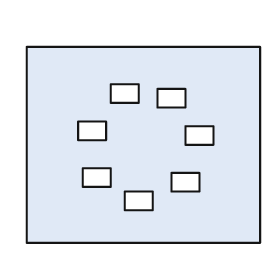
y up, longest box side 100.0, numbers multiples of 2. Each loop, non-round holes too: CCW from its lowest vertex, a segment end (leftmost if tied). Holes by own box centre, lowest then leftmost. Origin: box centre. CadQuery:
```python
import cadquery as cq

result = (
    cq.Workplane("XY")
    .moveTo(-50.0, -42.0)
    .lineTo(50.0, -42.0)
    .lineTo(50.0, 42.0)
    .lineTo(-50.0, 42.0)
    .close()
    .moveTo(-8.0, -28.0)
    .lineTo(4.0, -28.0)
    .lineTo(4.0, -20.0)
    .lineTo(-8.0, -20.0)
    .close()
    .moveTo(12.0, -20.0)
    .lineTo(24.0, -20.0)
    .lineTo(24.0, -12.0)
    .lineTo(12.0, -12.0)
    .close()
    .moveTo(-26.0, -18.0)
    .lineTo(-14.0, -18.0)
    .lineTo(-14.0, -10.0)
    .lineTo(-26.0, -10.0)
    .close()
    .moveTo(18.0, 0.0)
    .lineTo(30.0, 0.0)
    .lineTo(30.0, 8.0)
    .lineTo(18.0, 8.0)
    .close()
    .moveTo(-28.0, 2.0)
    .lineTo(-16.0, 2.0)
    .lineTo(-16.0, 10.0)
    .lineTo(-28.0, 10.0)
    .close()
    .moveTo(6.0, 16.0)
    .lineTo(18.0, 16.0)
    .lineTo(18.0, 24.0)
    .lineTo(6.0, 24.0)
    .close()
    .moveTo(-14.0, 18.0)
    .lineTo(-2.0, 18.0)
    .lineTo(-2.0, 26.0)
    .lineTo(-14.0, 26.0)
    .close()
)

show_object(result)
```